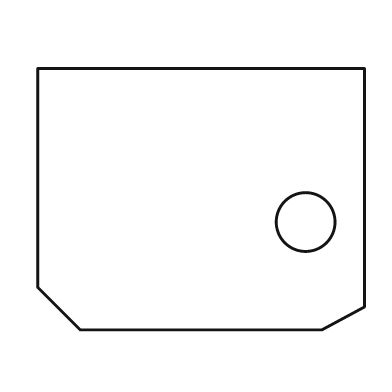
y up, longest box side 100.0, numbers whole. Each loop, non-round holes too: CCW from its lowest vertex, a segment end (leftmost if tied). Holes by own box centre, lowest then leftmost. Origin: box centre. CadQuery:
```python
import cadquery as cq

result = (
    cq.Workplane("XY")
    .moveTo(-37.0, -40.0)
    .lineTo(37.0, -40.0)
    .lineTo(50.0, -33.0)
    .lineTo(50.0, 40.0)
    .lineTo(-50.0, 40.0)
    .lineTo(-50.0, -27.0)
    .close()
    .moveTo(32.0, -7.0)
    .circle(9.0)
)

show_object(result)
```